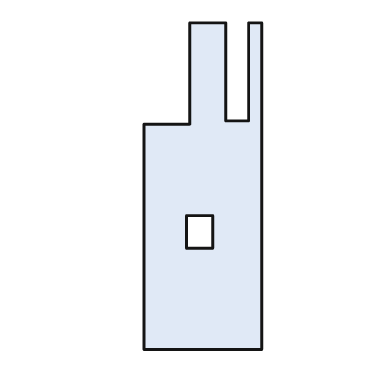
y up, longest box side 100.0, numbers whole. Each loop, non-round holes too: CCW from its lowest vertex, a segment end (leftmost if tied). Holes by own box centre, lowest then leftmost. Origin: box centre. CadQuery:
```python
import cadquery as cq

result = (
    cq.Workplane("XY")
    .moveTo(-18.0, -50.0)
    .lineTo(18.0, -50.0)
    .lineTo(18.0, 50.0)
    .lineTo(14.0, 50.0)
    .lineTo(14.0, 20.0)
    .lineTo(7.0, 20.0)
    .lineTo(7.0, 50.0)
    .lineTo(-4.0, 50.0)
    .lineTo(-4.0, 19.0)
    .lineTo(-18.0, 19.0)
    .close()
    .moveTo(-5.0, -19.0)
    .lineTo(3.0, -19.0)
    .lineTo(3.0, -9.0)
    .lineTo(-5.0, -9.0)
    .close()
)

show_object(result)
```